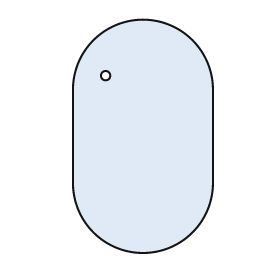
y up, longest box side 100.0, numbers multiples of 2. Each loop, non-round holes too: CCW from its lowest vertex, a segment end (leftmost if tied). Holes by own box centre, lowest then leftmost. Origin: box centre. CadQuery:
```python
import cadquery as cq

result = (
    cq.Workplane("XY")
    .moveTo(-30.0, -20.0)
    .threePointArc((0.0, -50.0), (30.0, -20.0))
    .lineTo(30.0, 20.0)
    .threePointArc((0.0, 50.0), (-30.0, 20.0))
    .close()
    .moveTo(-16.0, 26.0)
    .circle(2.0)
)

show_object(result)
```